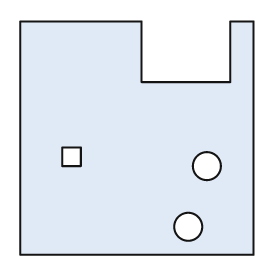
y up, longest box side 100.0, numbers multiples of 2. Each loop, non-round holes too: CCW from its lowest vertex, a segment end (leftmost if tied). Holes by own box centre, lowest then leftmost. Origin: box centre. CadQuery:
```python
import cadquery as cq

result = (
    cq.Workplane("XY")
    .moveTo(-50.0, -50.0)
    .lineTo(50.0, -50.0)
    .lineTo(50.0, 50.0)
    .lineTo(40.0, 50.0)
    .lineTo(40.0, 24.0)
    .lineTo(2.0, 24.0)
    .lineTo(2.0, 50.0)
    .lineTo(-50.0, 50.0)
    .close()
    .moveTo(22.0, -38.0)
    .circle(6.0)
    .moveTo(30.0, -12.0)
    .circle(6.0)
    .moveTo(-32.0, -12.0)
    .lineTo(-24.0, -12.0)
    .lineTo(-24.0, -4.0)
    .lineTo(-32.0, -4.0)
    .close()
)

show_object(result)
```